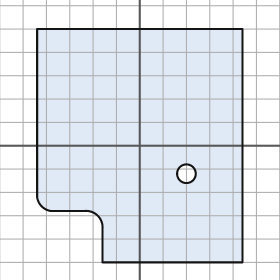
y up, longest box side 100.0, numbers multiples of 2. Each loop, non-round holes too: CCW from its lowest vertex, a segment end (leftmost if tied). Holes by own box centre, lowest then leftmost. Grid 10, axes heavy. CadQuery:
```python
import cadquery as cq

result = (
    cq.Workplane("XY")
    .moveTo(-16.0, -50.0)
    .lineTo(44.0, -50.0)
    .lineTo(44.0, 50.0)
    .lineTo(-44.0, 50.0)
    .lineTo(-44.0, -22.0)
    .threePointArc((-42.0, -26.0), (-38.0, -28.0))
    .lineTo(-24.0, -28.0)
    .threePointArc((-18.0, -30.0), (-16.0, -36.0))
    .close()
    .moveTo(20.0, -12.0)
    .circle(4.0)
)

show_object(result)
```